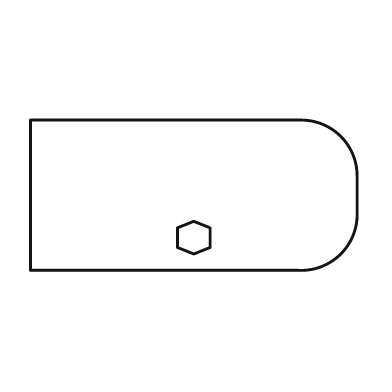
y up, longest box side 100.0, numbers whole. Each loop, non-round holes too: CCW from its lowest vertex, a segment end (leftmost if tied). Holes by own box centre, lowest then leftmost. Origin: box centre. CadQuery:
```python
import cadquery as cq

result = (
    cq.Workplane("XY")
    .moveTo(-50.0, -23.0)
    .lineTo(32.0, -23.0)
    .threePointArc((45.0, -18.0), (50.0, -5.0))
    .lineTo(50.0, 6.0)
    .threePointArc((45.0, 18.0), (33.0, 23.0))
    .lineTo(-50.0, 23.0)
    .close()
    .moveTo(0.0, -18.0)
    .lineTo(5.0, -16.0)
    .lineTo(5.0, -10.0)
    .lineTo(0.0, -8.0)
    .lineTo(-5.0, -10.0)
    .lineTo(-5.0, -16.0)
    .close()
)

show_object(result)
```